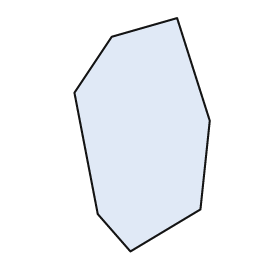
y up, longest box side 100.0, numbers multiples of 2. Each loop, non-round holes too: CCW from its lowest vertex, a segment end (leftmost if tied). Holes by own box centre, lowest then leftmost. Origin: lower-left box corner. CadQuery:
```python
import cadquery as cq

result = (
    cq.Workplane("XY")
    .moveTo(24.0, 0.0)
    .lineTo(54.0, 18.0)
    .lineTo(58.0, 56.0)
    .lineTo(44.0, 100.0)
    .lineTo(16.0, 92.0)
    .lineTo(0.0, 68.0)
    .lineTo(10.0, 16.0)
    .close()
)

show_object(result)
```